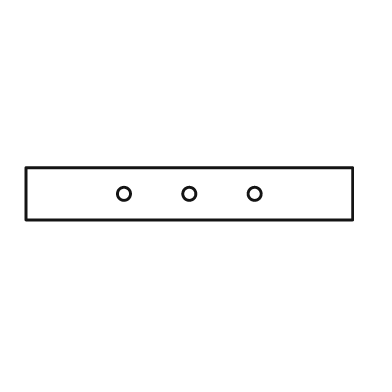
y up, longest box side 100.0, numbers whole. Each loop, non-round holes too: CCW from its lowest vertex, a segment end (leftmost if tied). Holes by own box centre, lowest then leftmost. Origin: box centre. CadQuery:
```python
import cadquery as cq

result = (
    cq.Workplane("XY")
    .moveTo(-50.0, -8.0)
    .lineTo(50.0, -8.0)
    .lineTo(50.0, 8.0)
    .lineTo(-50.0, 8.0)
    .close()
    .moveTo(-20.0, 0.0)
    .circle(2.0)
    .moveTo(0.0, 0.0)
    .circle(2.0)
    .moveTo(20.0, 0.0)
    .circle(2.0)
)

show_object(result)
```